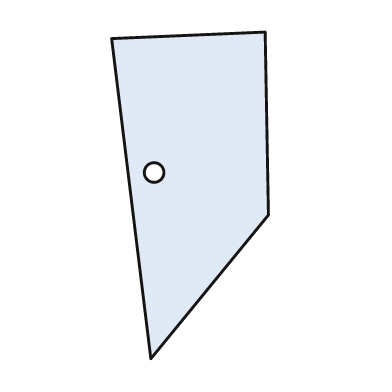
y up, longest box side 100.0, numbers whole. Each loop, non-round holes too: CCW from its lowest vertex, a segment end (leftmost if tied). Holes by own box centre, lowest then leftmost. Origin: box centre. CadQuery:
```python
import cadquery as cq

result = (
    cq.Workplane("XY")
    .moveTo(-12.0, -50.0)
    .lineTo(24.0, -6.0)
    .lineTo(23.0, 50.0)
    .lineTo(-24.0, 48.0)
    .close()
    .moveTo(-11.0, 7.0)
    .circle(3.0)
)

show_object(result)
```